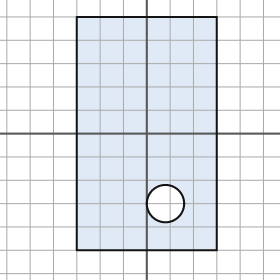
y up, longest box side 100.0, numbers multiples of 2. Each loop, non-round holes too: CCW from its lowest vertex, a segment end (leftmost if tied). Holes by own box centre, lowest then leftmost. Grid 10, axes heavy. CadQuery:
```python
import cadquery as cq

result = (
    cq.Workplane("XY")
    .moveTo(-30.0, -50.0)
    .lineTo(30.0, -50.0)
    .lineTo(30.0, 50.0)
    .lineTo(-30.0, 50.0)
    .close()
    .moveTo(8.0, -30.0)
    .circle(8.0)
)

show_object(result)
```